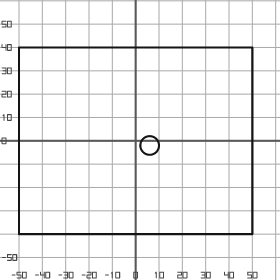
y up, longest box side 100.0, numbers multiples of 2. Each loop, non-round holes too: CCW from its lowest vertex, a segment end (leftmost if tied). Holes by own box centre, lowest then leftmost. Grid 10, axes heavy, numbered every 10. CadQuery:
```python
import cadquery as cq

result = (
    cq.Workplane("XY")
    .moveTo(-50.0, -40.0)
    .lineTo(50.0, -40.0)
    .lineTo(50.0, 40.0)
    .lineTo(-50.0, 40.0)
    .close()
    .moveTo(6.0, -2.0)
    .circle(4.0)
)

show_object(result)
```